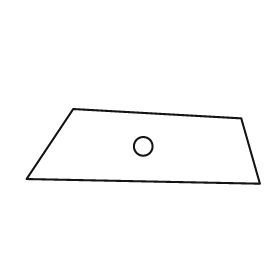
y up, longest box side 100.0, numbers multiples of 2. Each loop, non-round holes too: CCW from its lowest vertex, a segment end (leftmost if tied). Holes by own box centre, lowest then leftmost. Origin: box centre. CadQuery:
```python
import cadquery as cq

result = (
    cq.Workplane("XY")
    .moveTo(50.0, -16.0)
    .lineTo(42.0, 12.0)
    .lineTo(-30.0, 16.0)
    .lineTo(-50.0, -14.0)
    .close()
    .moveTo(0.0, 0.0)
    .circle(4.0)
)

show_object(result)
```